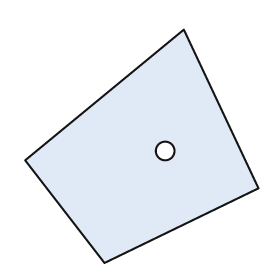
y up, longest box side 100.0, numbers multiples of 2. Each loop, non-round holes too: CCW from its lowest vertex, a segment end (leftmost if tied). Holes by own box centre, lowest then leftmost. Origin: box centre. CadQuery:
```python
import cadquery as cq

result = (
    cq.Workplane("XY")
    .moveTo(-16.0, -50.0)
    .lineTo(50.0, -18.0)
    .lineTo(18.0, 50.0)
    .lineTo(-50.0, -6.0)
    .close()
    .moveTo(10.0, -2.0)
    .circle(4.0)
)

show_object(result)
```